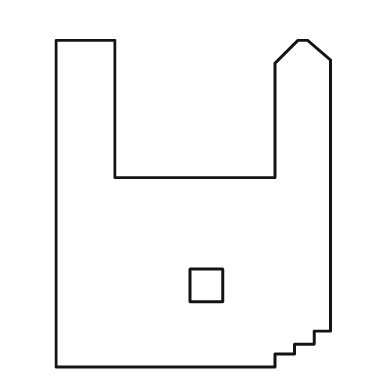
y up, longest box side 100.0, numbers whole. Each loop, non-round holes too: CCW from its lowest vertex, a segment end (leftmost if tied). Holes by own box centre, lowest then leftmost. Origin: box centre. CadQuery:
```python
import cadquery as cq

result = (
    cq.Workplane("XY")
    .moveTo(-42.0, -50.0)
    .lineTo(25.0, -50.0)
    .lineTo(25.0, -46.0)
    .lineTo(31.0, -46.0)
    .lineTo(31.0, -43.0)
    .lineTo(37.0, -43.0)
    .lineTo(37.0, -39.0)
    .lineTo(42.0, -39.0)
    .lineTo(42.0, 44.0)
    .lineTo(35.0, 50.0)
    .lineTo(32.0, 50.0)
    .lineTo(25.0, 43.0)
    .lineTo(25.0, 8.0)
    .lineTo(-24.0, 8.0)
    .lineTo(-24.0, 50.0)
    .lineTo(-42.0, 50.0)
    .close()
    .moveTo(-1.0, -30.0)
    .lineTo(9.0, -30.0)
    .lineTo(9.0, -20.0)
    .lineTo(-1.0, -20.0)
    .close()
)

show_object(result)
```